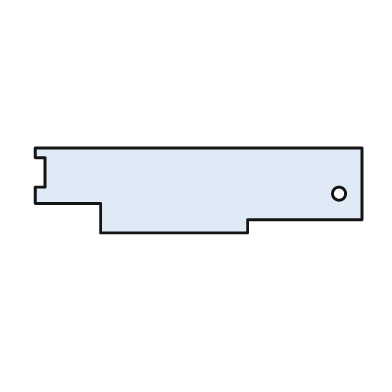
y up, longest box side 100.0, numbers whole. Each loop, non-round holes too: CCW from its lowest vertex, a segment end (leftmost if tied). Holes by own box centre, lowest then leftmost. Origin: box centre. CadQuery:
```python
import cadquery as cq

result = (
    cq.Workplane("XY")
    .moveTo(-30.0, -13.0)
    .lineTo(15.0, -13.0)
    .lineTo(15.0, -9.0)
    .lineTo(50.0, -9.0)
    .lineTo(50.0, 13.0)
    .lineTo(-50.0, 13.0)
    .lineTo(-50.0, 10.0)
    .lineTo(-47.0, 10.0)
    .lineTo(-47.0, 1.0)
    .lineTo(-50.0, 1.0)
    .lineTo(-50.0, -4.0)
    .lineTo(-30.0, -4.0)
    .close()
    .moveTo(43.0, -1.0)
    .circle(2.0)
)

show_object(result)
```